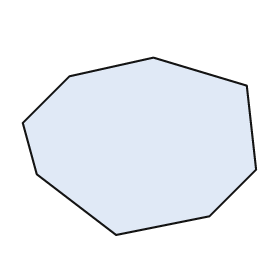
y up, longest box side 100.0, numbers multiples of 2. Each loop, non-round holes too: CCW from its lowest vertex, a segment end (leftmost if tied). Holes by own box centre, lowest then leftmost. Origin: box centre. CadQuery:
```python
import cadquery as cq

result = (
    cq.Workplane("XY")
    .moveTo(-10.0, -38.0)
    .lineTo(30.0, -30.0)
    .lineTo(50.0, -10.0)
    .lineTo(46.0, 26.0)
    .lineTo(6.0, 38.0)
    .lineTo(-30.0, 30.0)
    .lineTo(-50.0, 10.0)
    .lineTo(-44.0, -12.0)
    .close()
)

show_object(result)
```